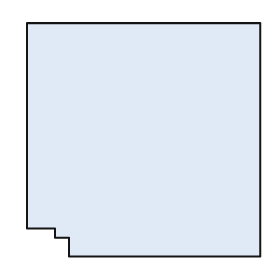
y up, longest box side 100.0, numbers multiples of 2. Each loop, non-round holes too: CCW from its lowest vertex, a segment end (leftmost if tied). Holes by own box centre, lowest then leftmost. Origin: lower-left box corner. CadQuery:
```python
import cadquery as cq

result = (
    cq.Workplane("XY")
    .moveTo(18.0, 0.0)
    .lineTo(100.0, 0.0)
    .lineTo(100.0, 100.0)
    .lineTo(0.0, 100.0)
    .lineTo(0.0, 12.0)
    .lineTo(12.0, 12.0)
    .lineTo(12.0, 8.0)
    .lineTo(18.0, 8.0)
    .close()
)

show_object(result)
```